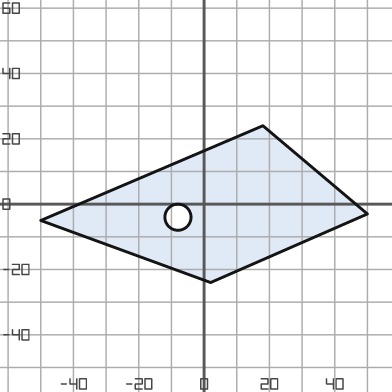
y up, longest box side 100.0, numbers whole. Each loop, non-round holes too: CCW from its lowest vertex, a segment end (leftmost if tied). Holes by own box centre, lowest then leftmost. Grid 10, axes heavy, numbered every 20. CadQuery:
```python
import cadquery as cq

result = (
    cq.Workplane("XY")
    .moveTo(2.0, -24.0)
    .lineTo(50.0, -3.0)
    .lineTo(18.0, 24.0)
    .lineTo(-50.0, -5.0)
    .close()
    .moveTo(-8.0, -4.0)
    .circle(4.0)
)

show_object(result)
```